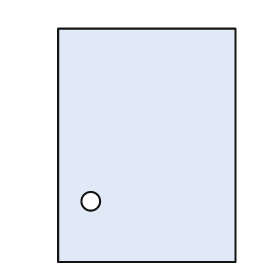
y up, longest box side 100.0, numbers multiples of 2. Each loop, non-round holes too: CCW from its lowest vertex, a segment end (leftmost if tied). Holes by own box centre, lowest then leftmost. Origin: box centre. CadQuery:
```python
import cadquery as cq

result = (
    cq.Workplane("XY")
    .moveTo(-38.0, -50.0)
    .lineTo(38.0, -50.0)
    .lineTo(38.0, 50.0)
    .lineTo(-38.0, 50.0)
    .close()
    .moveTo(-24.0, -24.0)
    .circle(4.0)
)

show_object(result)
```